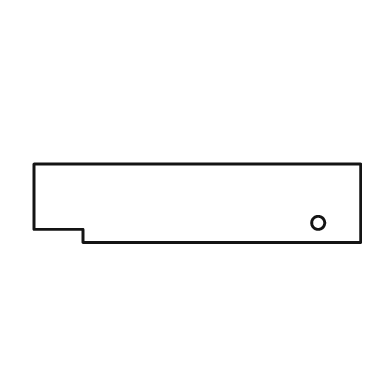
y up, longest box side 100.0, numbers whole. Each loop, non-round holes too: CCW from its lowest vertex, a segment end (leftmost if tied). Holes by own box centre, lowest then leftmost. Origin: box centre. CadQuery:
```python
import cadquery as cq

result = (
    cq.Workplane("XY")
    .moveTo(-35.0, -12.0)
    .lineTo(50.0, -12.0)
    .lineTo(50.0, 12.0)
    .lineTo(-50.0, 12.0)
    .lineTo(-50.0, -8.0)
    .lineTo(-35.0, -8.0)
    .close()
    .moveTo(37.0, -6.0)
    .circle(2.0)
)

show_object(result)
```